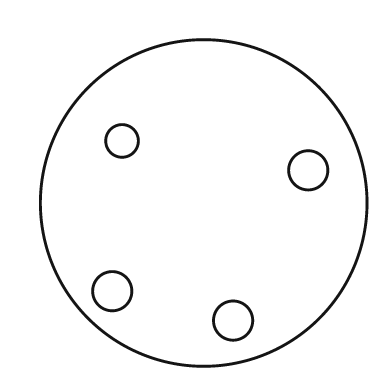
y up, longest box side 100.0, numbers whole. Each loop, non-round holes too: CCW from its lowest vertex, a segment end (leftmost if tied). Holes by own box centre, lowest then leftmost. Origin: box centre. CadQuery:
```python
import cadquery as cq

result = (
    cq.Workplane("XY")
    .moveTo(0.0, 0.0)
    .circle(50.0)
    .moveTo(9.0, -36.0)
    .circle(6.0)
    .moveTo(-28.0, -27.0)
    .circle(6.0)
    .moveTo(32.0, 10.0)
    .circle(6.0)
    .moveTo(-25.0, 19.0)
    .circle(5.0)
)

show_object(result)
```